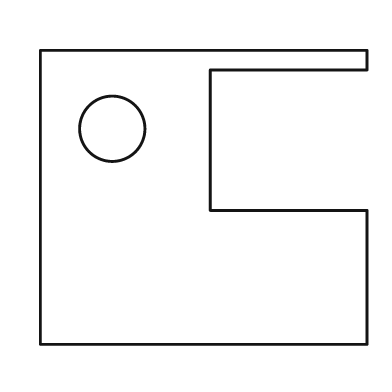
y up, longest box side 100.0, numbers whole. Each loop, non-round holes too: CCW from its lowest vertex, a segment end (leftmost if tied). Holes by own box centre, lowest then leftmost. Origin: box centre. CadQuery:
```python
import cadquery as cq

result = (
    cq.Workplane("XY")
    .moveTo(-50.0, -45.0)
    .lineTo(50.0, -45.0)
    .lineTo(50.0, -4.0)
    .lineTo(2.0, -4.0)
    .lineTo(2.0, 39.0)
    .lineTo(50.0, 39.0)
    .lineTo(50.0, 45.0)
    .lineTo(-50.0, 45.0)
    .close()
    .moveTo(-28.0, 21.0)
    .circle(10.0)
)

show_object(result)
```